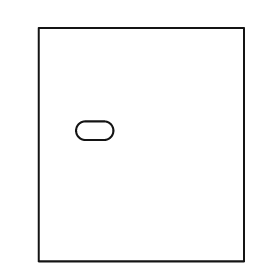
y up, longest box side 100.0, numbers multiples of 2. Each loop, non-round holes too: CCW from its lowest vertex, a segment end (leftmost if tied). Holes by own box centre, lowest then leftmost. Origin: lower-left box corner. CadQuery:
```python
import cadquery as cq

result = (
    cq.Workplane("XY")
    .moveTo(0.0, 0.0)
    .lineTo(88.0, 0.0)
    .lineTo(88.0, 100.0)
    .lineTo(0.0, 100.0)
    .close()
    .moveTo(20.0, 52.0)
    .lineTo(28.0, 52.0)
    .threePointArc((32.0, 56.0), (28.0, 60.0))
    .lineTo(20.0, 60.0)
    .threePointArc((16.0, 56.0), (20.0, 52.0))
    .close()
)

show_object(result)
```